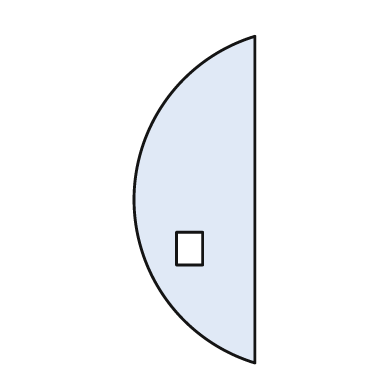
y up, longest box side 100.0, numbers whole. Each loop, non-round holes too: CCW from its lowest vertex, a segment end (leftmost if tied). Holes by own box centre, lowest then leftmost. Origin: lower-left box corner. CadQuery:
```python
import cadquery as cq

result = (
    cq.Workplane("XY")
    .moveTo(37.0, 0.0)
    .lineTo(37.0, 100.0)
    .threePointArc((0.0, 50.0), (37.0, 0.0))
    .close()
    .moveTo(13.0, 30.0)
    .lineTo(21.0, 30.0)
    .lineTo(21.0, 40.0)
    .lineTo(13.0, 40.0)
    .close()
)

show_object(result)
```